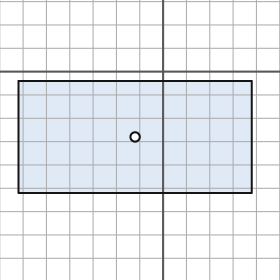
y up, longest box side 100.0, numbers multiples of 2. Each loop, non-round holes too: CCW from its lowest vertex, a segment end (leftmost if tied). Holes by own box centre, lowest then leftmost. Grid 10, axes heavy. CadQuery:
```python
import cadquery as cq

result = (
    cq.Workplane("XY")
    .moveTo(-62.0, -52.0)
    .lineTo(38.0, -52.0)
    .lineTo(38.0, -4.0)
    .lineTo(-62.0, -4.0)
    .close()
    .moveTo(-12.0, -28.0)
    .circle(2.0)
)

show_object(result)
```